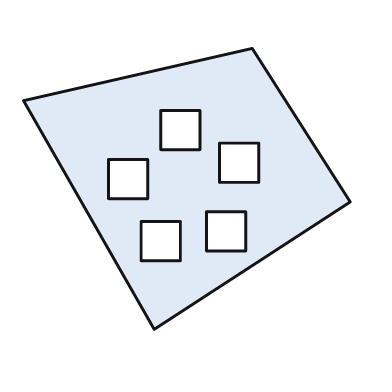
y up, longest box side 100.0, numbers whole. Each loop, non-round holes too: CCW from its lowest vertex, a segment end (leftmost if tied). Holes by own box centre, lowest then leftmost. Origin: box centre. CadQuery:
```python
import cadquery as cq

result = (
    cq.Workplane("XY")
    .moveTo(-10.0, -43.0)
    .lineTo(50.0, -4.0)
    .lineTo(20.0, 43.0)
    .lineTo(-50.0, 27.0)
    .close()
    .moveTo(-14.0, -22.0)
    .lineTo(-2.0, -22.0)
    .lineTo(-2.0, -10.0)
    .lineTo(-14.0, -10.0)
    .close()
    .moveTo(6.0, -19.0)
    .lineTo(18.0, -19.0)
    .lineTo(18.0, -7.0)
    .lineTo(6.0, -7.0)
    .close()
    .moveTo(-24.0, -3.0)
    .lineTo(-12.0, -3.0)
    .lineTo(-12.0, 9.0)
    .lineTo(-24.0, 9.0)
    .close()
    .moveTo(10.0, 2.0)
    .lineTo(22.0, 2.0)
    .lineTo(22.0, 14.0)
    .lineTo(10.0, 14.0)
    .close()
    .moveTo(-8.0, 12.0)
    .lineTo(4.0, 12.0)
    .lineTo(4.0, 24.0)
    .lineTo(-8.0, 24.0)
    .close()
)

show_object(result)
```